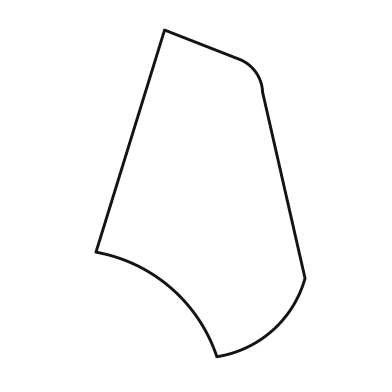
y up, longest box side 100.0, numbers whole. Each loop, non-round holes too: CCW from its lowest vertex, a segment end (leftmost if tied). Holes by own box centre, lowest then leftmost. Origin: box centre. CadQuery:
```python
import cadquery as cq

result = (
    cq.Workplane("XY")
    .moveTo(5.0, -50.0)
    .threePointArc((22.0, -42.0), (32.0, -26.0))
    .lineTo(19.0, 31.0)
    .threePointArc((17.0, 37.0), (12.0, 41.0))
    .lineTo(-11.0, 50.0)
    .lineTo(-32.0, -18.0)
    .threePointArc((-9.0, -29.0), (5.0, -50.0))
    .close()
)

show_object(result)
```